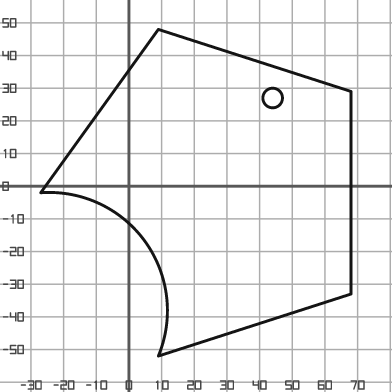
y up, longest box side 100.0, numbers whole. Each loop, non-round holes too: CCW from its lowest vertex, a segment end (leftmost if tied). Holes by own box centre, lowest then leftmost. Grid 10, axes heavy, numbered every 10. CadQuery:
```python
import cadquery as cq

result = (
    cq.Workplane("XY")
    .moveTo(9.0, -52.0)
    .lineTo(68.0, -33.0)
    .lineTo(68.0, 29.0)
    .lineTo(9.0, 48.0)
    .lineTo(-27.0, -2.0)
    .threePointArc((5.0, -17.0), (9.0, -52.0))
    .close()
    .moveTo(44.0, 27.0)
    .circle(3.0)
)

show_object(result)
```